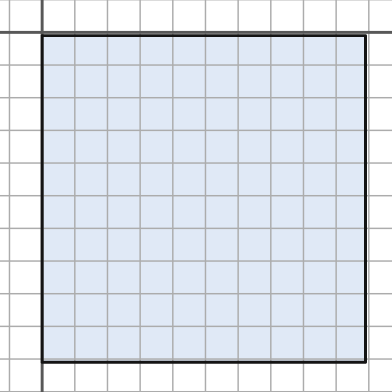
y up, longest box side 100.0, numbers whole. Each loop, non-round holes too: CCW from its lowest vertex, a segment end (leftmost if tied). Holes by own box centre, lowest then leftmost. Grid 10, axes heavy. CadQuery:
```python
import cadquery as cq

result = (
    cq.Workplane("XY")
    .moveTo(0.0, -101.0)
    .lineTo(99.0, -101.0)
    .lineTo(99.0, -1.0)
    .lineTo(0.0, -1.0)
    .close()
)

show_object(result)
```